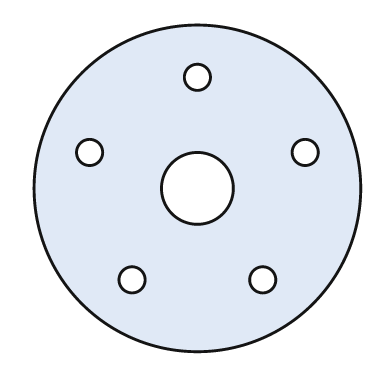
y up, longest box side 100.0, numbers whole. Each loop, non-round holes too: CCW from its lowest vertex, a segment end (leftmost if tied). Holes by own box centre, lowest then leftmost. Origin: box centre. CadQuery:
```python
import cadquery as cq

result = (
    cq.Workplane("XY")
    .moveTo(0.0, 0.0)
    .circle(50.0)
    .moveTo(-20.0, -28.0)
    .circle(4.0)
    .moveTo(20.0, -28.0)
    .circle(4.0)
    .moveTo(0.0, 0.0)
    .circle(11.0)
    .moveTo(-33.0, 11.0)
    .circle(4.0)
    .moveTo(33.0, 11.0)
    .circle(4.0)
    .moveTo(0.0, 34.0)
    .circle(4.0)
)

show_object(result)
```